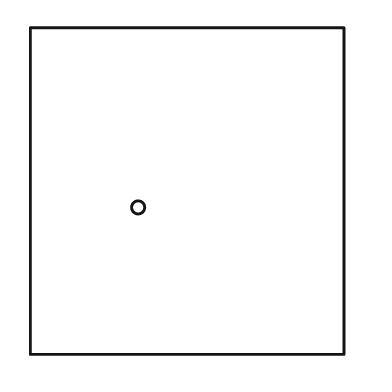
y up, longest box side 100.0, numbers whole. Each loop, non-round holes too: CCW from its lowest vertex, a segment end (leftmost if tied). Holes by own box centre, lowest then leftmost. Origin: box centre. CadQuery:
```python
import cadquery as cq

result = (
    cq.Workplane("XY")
    .moveTo(-48.0, -50.0)
    .lineTo(48.0, -50.0)
    .lineTo(48.0, 50.0)
    .lineTo(-48.0, 50.0)
    .close()
    .moveTo(-15.0, -5.0)
    .circle(2.0)
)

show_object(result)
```